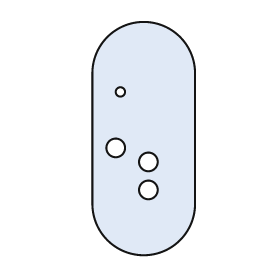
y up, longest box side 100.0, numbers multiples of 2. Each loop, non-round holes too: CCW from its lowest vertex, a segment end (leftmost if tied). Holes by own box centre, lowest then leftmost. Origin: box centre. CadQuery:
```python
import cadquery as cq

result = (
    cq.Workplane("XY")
    .moveTo(-22.0, -28.0)
    .threePointArc((0.0, -50.0), (22.0, -28.0))
    .lineTo(22.0, 28.0)
    .threePointArc((0.0, 50.0), (-22.0, 28.0))
    .close()
    .moveTo(2.0, -22.0)
    .circle(4.0)
    .moveTo(2.0, -10.0)
    .circle(4.0)
    .moveTo(-12.0, -4.0)
    .circle(4.0)
    .moveTo(-10.0, 20.0)
    .circle(2.0)
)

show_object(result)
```